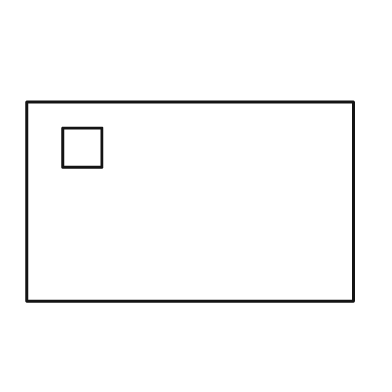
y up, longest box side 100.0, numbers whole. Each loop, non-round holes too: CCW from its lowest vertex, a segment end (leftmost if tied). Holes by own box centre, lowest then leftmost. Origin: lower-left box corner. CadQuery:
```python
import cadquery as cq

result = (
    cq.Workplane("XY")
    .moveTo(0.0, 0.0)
    .lineTo(100.0, 0.0)
    .lineTo(100.0, 61.0)
    .lineTo(0.0, 61.0)
    .close()
    .moveTo(11.0, 41.0)
    .lineTo(23.0, 41.0)
    .lineTo(23.0, 53.0)
    .lineTo(11.0, 53.0)
    .close()
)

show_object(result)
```